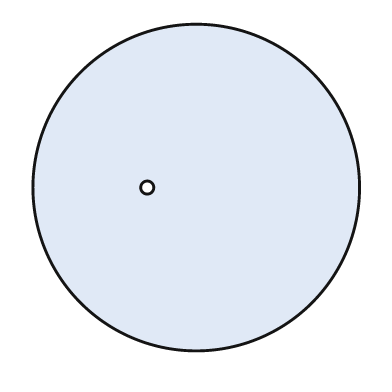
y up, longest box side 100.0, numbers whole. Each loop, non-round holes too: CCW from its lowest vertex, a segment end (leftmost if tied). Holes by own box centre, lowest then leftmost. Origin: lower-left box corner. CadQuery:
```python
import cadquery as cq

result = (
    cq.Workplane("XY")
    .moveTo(50.0, 50.0)
    .circle(50.0)
    .moveTo(35.0, 50.0)
    .circle(2.0)
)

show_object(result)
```